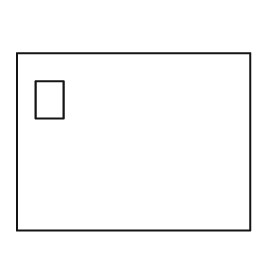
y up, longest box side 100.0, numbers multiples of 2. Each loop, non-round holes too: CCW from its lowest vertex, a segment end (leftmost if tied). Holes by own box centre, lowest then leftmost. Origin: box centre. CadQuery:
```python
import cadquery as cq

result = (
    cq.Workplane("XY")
    .moveTo(-50.0, -38.0)
    .lineTo(50.0, -38.0)
    .lineTo(50.0, 38.0)
    .lineTo(-50.0, 38.0)
    .close()
    .moveTo(-42.0, 10.0)
    .lineTo(-30.0, 10.0)
    .lineTo(-30.0, 26.0)
    .lineTo(-42.0, 26.0)
    .close()
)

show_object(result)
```